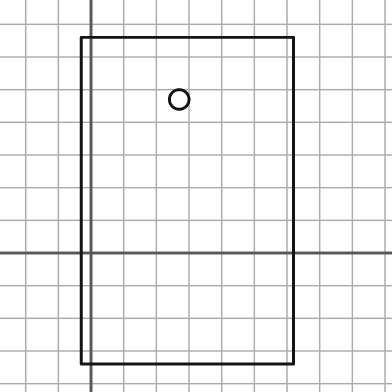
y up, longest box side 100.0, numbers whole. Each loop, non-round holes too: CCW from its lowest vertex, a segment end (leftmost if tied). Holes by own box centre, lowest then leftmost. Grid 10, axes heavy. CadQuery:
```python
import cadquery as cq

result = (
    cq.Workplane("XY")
    .moveTo(-3.0, -34.0)
    .lineTo(62.0, -34.0)
    .lineTo(62.0, 66.0)
    .lineTo(-3.0, 66.0)
    .close()
    .moveTo(27.0, 47.0)
    .circle(3.0)
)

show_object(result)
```